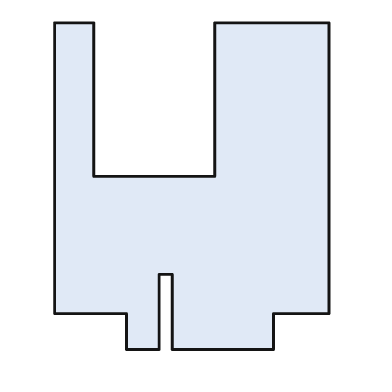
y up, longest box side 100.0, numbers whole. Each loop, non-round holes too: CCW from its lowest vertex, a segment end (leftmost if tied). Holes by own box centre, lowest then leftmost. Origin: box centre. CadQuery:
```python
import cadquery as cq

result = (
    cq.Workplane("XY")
    .moveTo(-20.0, -50.0)
    .lineTo(-10.0, -50.0)
    .lineTo(-10.0, -27.0)
    .lineTo(-6.0, -27.0)
    .lineTo(-6.0, -50.0)
    .lineTo(25.0, -50.0)
    .lineTo(25.0, -39.0)
    .lineTo(42.0, -39.0)
    .lineTo(42.0, 50.0)
    .lineTo(7.0, 50.0)
    .lineTo(7.0, 3.0)
    .lineTo(-30.0, 3.0)
    .lineTo(-30.0, 50.0)
    .lineTo(-42.0, 50.0)
    .lineTo(-42.0, -39.0)
    .lineTo(-20.0, -39.0)
    .close()
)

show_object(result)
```